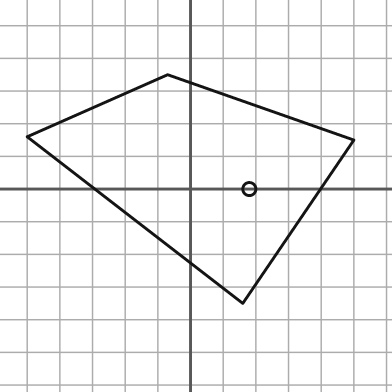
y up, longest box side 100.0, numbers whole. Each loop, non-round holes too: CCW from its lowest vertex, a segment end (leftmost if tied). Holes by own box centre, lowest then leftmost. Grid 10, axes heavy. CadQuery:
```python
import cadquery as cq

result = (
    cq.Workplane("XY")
    .moveTo(16.0, -35.0)
    .lineTo(50.0, 15.0)
    .lineTo(-7.0, 35.0)
    .lineTo(-50.0, 16.0)
    .close()
    .moveTo(18.0, 0.0)
    .circle(2.0)
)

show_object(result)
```